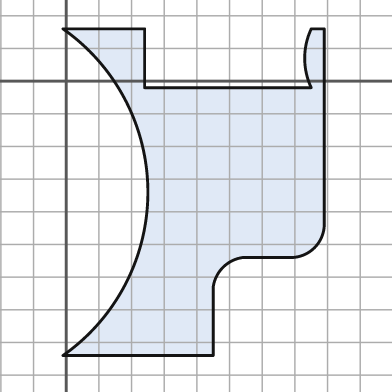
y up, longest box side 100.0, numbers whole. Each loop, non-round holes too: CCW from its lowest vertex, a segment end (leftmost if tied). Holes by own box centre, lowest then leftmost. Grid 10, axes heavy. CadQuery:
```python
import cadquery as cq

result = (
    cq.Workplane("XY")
    .moveTo(-1.0, -84.0)
    .lineTo(45.0, -84.0)
    .lineTo(45.0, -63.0)
    .threePointArc((48.0, -57.0), (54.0, -54.0))
    .lineTo(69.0, -54.0)
    .threePointArc((76.0, -51.0), (79.0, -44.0))
    .lineTo(79.0, 16.0)
    .lineTo(75.0, 16.0)
    .threePointArc((73.0, 7.0), (75.0, -2.0))
    .lineTo(24.0, -2.0)
    .lineTo(24.0, 16.0)
    .lineTo(-1.0, 16.0)
    .threePointArc((25.0, -34.0), (-1.0, -84.0))
    .close()
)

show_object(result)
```